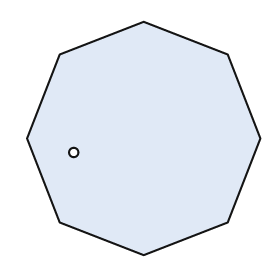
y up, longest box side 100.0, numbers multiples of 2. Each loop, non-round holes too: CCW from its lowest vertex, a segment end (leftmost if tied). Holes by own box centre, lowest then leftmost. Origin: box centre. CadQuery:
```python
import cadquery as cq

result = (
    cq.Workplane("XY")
    .moveTo(0.0, -50.0)
    .lineTo(36.0, -36.0)
    .lineTo(50.0, 0.0)
    .lineTo(36.0, 36.0)
    .lineTo(0.0, 50.0)
    .lineTo(-36.0, 36.0)
    .lineTo(-50.0, 0.0)
    .lineTo(-36.0, -36.0)
    .close()
    .moveTo(-30.0, -6.0)
    .circle(2.0)
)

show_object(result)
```